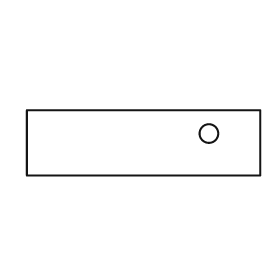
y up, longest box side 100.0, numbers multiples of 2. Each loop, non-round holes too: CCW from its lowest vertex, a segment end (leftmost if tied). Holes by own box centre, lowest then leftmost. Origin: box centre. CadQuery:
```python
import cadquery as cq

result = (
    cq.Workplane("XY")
    .moveTo(-50.0, -14.0)
    .lineTo(50.0, -14.0)
    .lineTo(50.0, 14.0)
    .lineTo(-50.0, 14.0)
    .close()
    .moveTo(28.0, 4.0)
    .circle(4.0)
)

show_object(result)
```